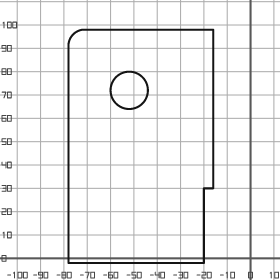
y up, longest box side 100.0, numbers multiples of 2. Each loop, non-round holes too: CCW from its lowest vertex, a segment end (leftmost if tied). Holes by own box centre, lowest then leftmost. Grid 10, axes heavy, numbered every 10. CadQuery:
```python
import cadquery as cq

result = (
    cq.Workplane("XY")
    .moveTo(-78.0, -2.0)
    .lineTo(-20.0, -2.0)
    .lineTo(-20.0, 30.0)
    .lineTo(-16.0, 30.0)
    .lineTo(-16.0, 98.0)
    .lineTo(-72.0, 98.0)
    .threePointArc((-76.0, 96.0), (-78.0, 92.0))
    .close()
    .moveTo(-52.0, 72.0)
    .circle(8.0)
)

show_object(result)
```